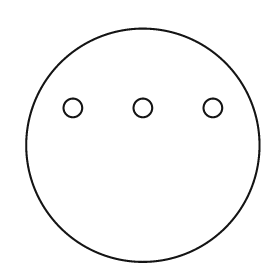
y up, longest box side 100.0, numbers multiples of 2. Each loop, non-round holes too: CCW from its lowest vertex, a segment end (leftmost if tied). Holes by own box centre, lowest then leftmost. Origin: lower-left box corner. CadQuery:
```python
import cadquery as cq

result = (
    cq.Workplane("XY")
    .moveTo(50.0, 50.0)
    .circle(50.0)
    .moveTo(20.0, 66.0)
    .circle(4.0)
    .moveTo(50.0, 66.0)
    .circle(4.0)
    .moveTo(80.0, 66.0)
    .circle(4.0)
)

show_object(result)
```